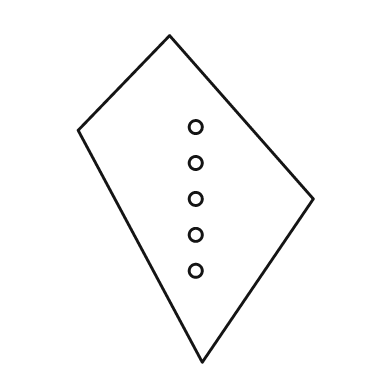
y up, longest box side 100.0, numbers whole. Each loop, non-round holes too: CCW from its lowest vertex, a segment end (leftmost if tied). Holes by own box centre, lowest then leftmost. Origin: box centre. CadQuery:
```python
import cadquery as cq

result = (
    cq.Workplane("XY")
    .moveTo(2.0, -50.0)
    .lineTo(36.0, 0.0)
    .lineTo(-8.0, 50.0)
    .lineTo(-36.0, 21.0)
    .close()
    .moveTo(0.0, -22.0)
    .circle(2.0)
    .moveTo(0.0, -11.0)
    .circle(2.0)
    .moveTo(0.0, 0.0)
    .circle(2.0)
    .moveTo(0.0, 11.0)
    .circle(2.0)
    .moveTo(0.0, 22.0)
    .circle(2.0)
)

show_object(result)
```